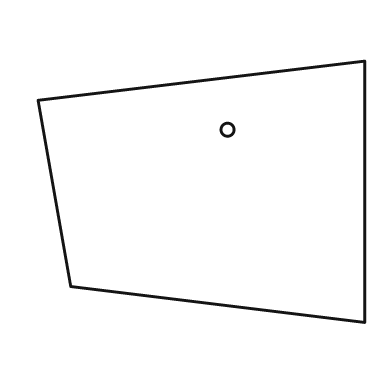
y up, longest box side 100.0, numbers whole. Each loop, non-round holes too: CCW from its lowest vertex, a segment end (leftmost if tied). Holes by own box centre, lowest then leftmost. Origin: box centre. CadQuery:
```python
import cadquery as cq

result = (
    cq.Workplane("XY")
    .moveTo(50.0, -40.0)
    .lineTo(50.0, 40.0)
    .lineTo(-50.0, 28.0)
    .lineTo(-40.0, -29.0)
    .close()
    .moveTo(8.0, 19.0)
    .circle(2.0)
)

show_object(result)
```